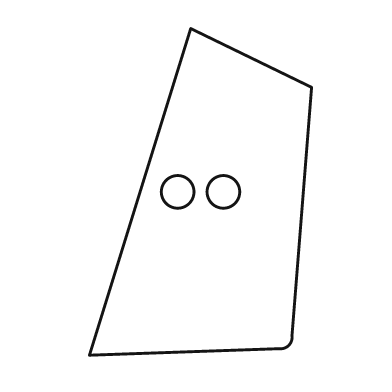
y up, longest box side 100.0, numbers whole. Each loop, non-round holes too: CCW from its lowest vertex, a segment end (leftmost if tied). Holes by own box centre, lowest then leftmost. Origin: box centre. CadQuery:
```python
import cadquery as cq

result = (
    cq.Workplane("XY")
    .moveTo(-34.0, -50.0)
    .lineTo(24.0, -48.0)
    .threePointArc((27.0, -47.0), (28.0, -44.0))
    .lineTo(34.0, 32.0)
    .lineTo(-3.0, 50.0)
    .close()
    .moveTo(-7.0, 0.0)
    .circle(5.0)
    .moveTo(7.0, 0.0)
    .circle(5.0)
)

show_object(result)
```